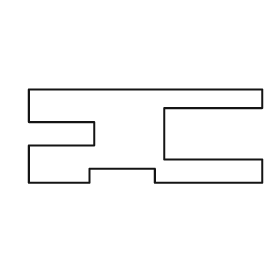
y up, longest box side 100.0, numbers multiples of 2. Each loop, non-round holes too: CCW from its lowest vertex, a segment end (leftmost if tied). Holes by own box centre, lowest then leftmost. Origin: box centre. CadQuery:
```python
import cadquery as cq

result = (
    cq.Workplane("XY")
    .moveTo(-50.0, -20.0)
    .lineTo(-24.0, -20.0)
    .lineTo(-24.0, -14.0)
    .lineTo(4.0, -14.0)
    .lineTo(4.0, -20.0)
    .lineTo(50.0, -20.0)
    .lineTo(50.0, -10.0)
    .lineTo(8.0, -10.0)
    .lineTo(8.0, 12.0)
    .lineTo(50.0, 12.0)
    .lineTo(50.0, 20.0)
    .lineTo(-50.0, 20.0)
    .lineTo(-50.0, 6.0)
    .lineTo(-22.0, 6.0)
    .lineTo(-22.0, -4.0)
    .lineTo(-50.0, -4.0)
    .close()
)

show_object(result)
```